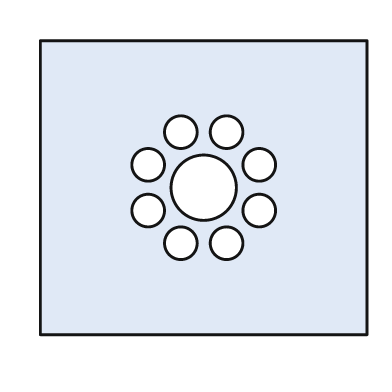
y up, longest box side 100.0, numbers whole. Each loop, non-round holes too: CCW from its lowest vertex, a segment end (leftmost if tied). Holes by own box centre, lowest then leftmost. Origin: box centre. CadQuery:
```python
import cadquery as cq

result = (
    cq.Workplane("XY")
    .moveTo(-50.0, -45.0)
    .lineTo(50.0, -45.0)
    .lineTo(50.0, 45.0)
    .lineTo(-50.0, 45.0)
    .close()
    .moveTo(-7.0, -17.0)
    .circle(5.0)
    .moveTo(7.0, -17.0)
    .circle(5.0)
    .moveTo(-17.0, -7.0)
    .circle(5.0)
    .moveTo(17.0, -7.0)
    .circle(5.0)
    .moveTo(0.0, 0.0)
    .circle(10.0)
    .moveTo(-17.0, 7.0)
    .circle(5.0)
    .moveTo(17.0, 7.0)
    .circle(5.0)
    .moveTo(-7.0, 17.0)
    .circle(5.0)
    .moveTo(7.0, 17.0)
    .circle(5.0)
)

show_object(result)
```